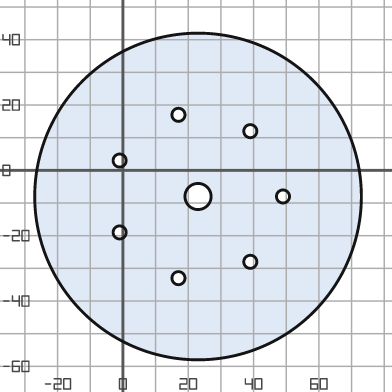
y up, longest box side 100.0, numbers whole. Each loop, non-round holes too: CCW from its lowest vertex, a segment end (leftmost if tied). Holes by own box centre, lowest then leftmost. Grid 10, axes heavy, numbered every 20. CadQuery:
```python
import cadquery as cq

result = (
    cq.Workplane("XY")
    .moveTo(23.0, -8.0)
    .circle(50.0)
    .moveTo(17.0, -33.0)
    .circle(2.0)
    .moveTo(39.0, -28.0)
    .circle(2.0)
    .moveTo(-1.0, -19.0)
    .circle(2.0)
    .moveTo(23.0, -8.0)
    .circle(4.0)
    .moveTo(49.0, -8.0)
    .circle(2.0)
    .moveTo(-1.0, 3.0)
    .circle(2.0)
    .moveTo(39.0, 12.0)
    .circle(2.0)
    .moveTo(17.0, 17.0)
    .circle(2.0)
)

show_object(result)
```